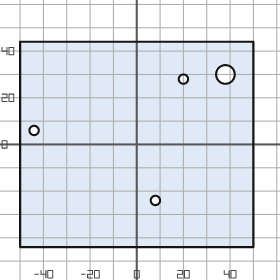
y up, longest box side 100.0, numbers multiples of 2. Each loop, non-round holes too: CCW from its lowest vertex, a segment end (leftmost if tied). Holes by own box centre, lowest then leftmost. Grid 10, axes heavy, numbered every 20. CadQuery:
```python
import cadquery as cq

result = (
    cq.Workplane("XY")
    .moveTo(-50.0, -44.0)
    .lineTo(50.0, -44.0)
    .lineTo(50.0, 44.0)
    .lineTo(-50.0, 44.0)
    .close()
    .moveTo(8.0, -24.0)
    .circle(2.0)
    .moveTo(-44.0, 6.0)
    .circle(2.0)
    .moveTo(20.0, 28.0)
    .circle(2.0)
    .moveTo(38.0, 30.0)
    .circle(4.0)
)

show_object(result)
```